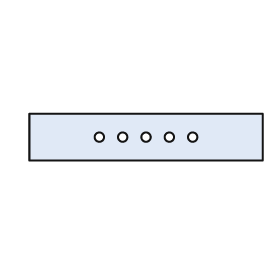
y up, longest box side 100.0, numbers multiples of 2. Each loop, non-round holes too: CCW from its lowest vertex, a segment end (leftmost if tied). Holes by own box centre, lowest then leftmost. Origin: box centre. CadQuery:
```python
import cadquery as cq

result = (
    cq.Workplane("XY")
    .moveTo(-50.0, -10.0)
    .lineTo(50.0, -10.0)
    .lineTo(50.0, 10.0)
    .lineTo(-50.0, 10.0)
    .close()
    .moveTo(-20.0, 0.0)
    .circle(2.0)
    .moveTo(-10.0, 0.0)
    .circle(2.0)
    .moveTo(0.0, 0.0)
    .circle(2.0)
    .moveTo(10.0, 0.0)
    .circle(2.0)
    .moveTo(20.0, 0.0)
    .circle(2.0)
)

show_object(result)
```